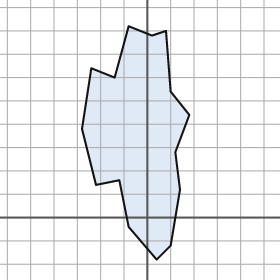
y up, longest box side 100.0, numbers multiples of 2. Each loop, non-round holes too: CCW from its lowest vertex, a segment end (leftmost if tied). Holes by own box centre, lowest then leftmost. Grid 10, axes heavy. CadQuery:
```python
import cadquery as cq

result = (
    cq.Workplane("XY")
    .moveTo(4.0, -18.0)
    .lineTo(10.0, -12.0)
    .lineTo(14.0, 12.0)
    .lineTo(12.0, 28.0)
    .lineTo(18.0, 44.0)
    .lineTo(10.0, 54.0)
    .lineTo(8.0, 80.0)
    .lineTo(2.0, 78.0)
    .lineTo(-8.0, 82.0)
    .lineTo(-14.0, 60.0)
    .lineTo(-24.0, 64.0)
    .lineTo(-28.0, 38.0)
    .lineTo(-22.0, 14.0)
    .lineTo(-12.0, 16.0)
    .lineTo(-8.0, -4.0)
    .close()
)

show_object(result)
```